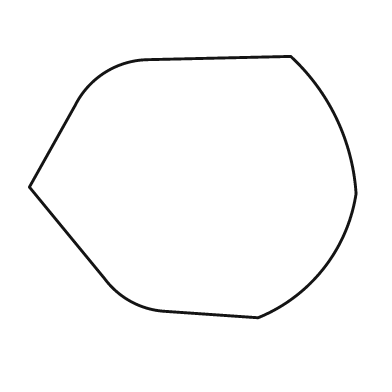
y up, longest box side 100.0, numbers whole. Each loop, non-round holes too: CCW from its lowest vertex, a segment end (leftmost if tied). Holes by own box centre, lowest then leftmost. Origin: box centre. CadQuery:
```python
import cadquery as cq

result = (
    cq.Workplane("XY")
    .moveTo(20.0, -40.0)
    .threePointArc((40.0, -25.0), (50.0, -2.0))
    .threePointArc((44.0, 21.0), (30.0, 40.0))
    .lineTo(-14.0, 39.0)
    .threePointArc((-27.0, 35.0), (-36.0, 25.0))
    .lineTo(-50.0, 0.0)
    .lineTo(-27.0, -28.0)
    .threePointArc((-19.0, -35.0), (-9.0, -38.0))
    .close()
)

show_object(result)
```